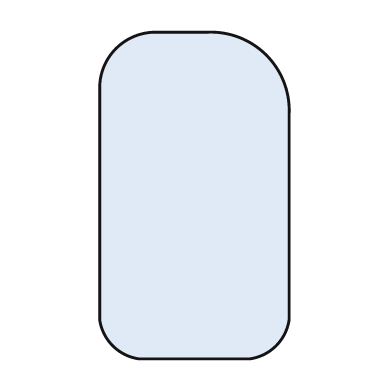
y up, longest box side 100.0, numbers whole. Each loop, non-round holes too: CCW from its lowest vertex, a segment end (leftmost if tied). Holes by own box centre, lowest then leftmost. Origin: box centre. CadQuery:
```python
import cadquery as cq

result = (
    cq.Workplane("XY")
    .moveTo(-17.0, -50.0)
    .lineTo(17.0, -50.0)
    .threePointArc((25.0, -46.0), (29.0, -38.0))
    .lineTo(29.0, 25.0)
    .threePointArc((22.0, 43.0), (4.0, 50.0))
    .lineTo(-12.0, 50.0)
    .threePointArc((-24.0, 45.0), (-29.0, 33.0))
    .lineTo(-29.0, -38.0)
    .threePointArc((-25.0, -46.0), (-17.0, -50.0))
    .close()
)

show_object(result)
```